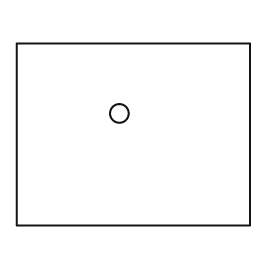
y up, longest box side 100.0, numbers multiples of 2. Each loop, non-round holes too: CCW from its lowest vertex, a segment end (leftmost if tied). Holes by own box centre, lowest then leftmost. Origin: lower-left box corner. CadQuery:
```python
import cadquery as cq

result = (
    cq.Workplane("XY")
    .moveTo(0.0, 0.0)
    .lineTo(100.0, 0.0)
    .lineTo(100.0, 78.0)
    .lineTo(0.0, 78.0)
    .close()
    .moveTo(44.0, 48.0)
    .circle(4.0)
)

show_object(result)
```